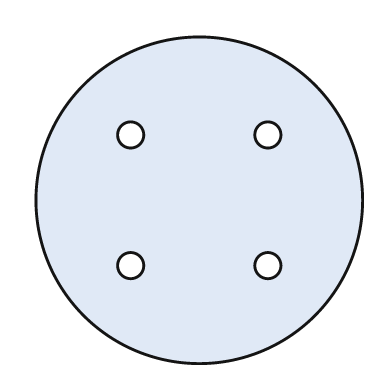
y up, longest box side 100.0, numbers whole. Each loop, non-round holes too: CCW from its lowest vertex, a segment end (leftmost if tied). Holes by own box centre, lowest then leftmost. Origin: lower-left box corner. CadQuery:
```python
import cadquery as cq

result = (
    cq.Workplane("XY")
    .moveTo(50.0, 50.0)
    .circle(50.0)
    .moveTo(29.0, 30.0)
    .circle(4.0)
    .moveTo(71.0, 30.0)
    .circle(4.0)
    .moveTo(29.0, 70.0)
    .circle(4.0)
    .moveTo(71.0, 70.0)
    .circle(4.0)
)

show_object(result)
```